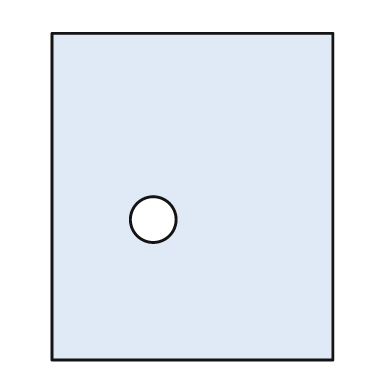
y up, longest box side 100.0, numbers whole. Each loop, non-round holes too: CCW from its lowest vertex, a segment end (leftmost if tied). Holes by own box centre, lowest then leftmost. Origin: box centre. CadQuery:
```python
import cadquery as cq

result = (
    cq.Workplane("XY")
    .moveTo(-43.0, -50.0)
    .lineTo(43.0, -50.0)
    .lineTo(43.0, 50.0)
    .lineTo(-43.0, 50.0)
    .close()
    .moveTo(-12.0, -7.0)
    .circle(7.0)
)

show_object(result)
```